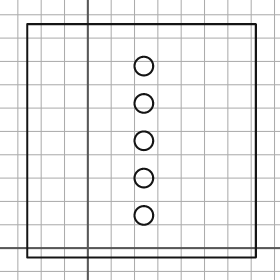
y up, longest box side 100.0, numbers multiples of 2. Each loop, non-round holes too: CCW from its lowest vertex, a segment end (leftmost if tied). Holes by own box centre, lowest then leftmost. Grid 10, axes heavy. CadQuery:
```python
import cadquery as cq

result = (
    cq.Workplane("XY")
    .moveTo(-26.0, -4.0)
    .lineTo(72.0, -4.0)
    .lineTo(72.0, 96.0)
    .lineTo(-26.0, 96.0)
    .close()
    .moveTo(24.0, 14.0)
    .circle(4.0)
    .moveTo(24.0, 30.0)
    .circle(4.0)
    .moveTo(24.0, 46.0)
    .circle(4.0)
    .moveTo(24.0, 62.0)
    .circle(4.0)
    .moveTo(24.0, 78.0)
    .circle(4.0)
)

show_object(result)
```